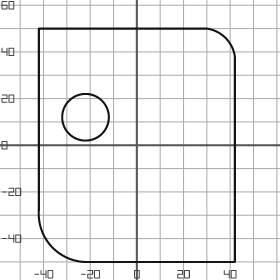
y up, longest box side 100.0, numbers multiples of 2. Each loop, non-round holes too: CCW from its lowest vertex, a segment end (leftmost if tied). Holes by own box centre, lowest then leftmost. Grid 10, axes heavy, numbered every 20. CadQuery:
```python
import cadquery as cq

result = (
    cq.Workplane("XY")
    .moveTo(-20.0, -50.0)
    .lineTo(42.0, -50.0)
    .lineTo(42.0, 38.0)
    .threePointArc((38.0, 46.0), (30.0, 50.0))
    .lineTo(-42.0, 50.0)
    .lineTo(-42.0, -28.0)
    .threePointArc((-36.0, -44.0), (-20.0, -50.0))
    .close()
    .moveTo(-22.0, 12.0)
    .circle(10.0)
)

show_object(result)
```